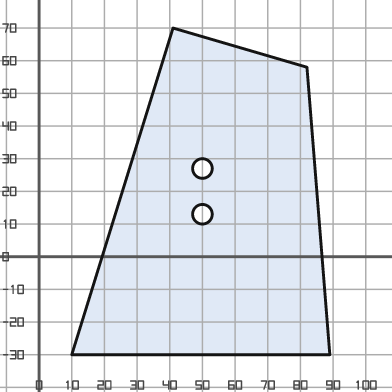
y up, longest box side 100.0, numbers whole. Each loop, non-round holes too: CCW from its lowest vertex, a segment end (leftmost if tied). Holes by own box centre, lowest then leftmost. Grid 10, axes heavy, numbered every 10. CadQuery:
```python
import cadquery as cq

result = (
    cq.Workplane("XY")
    .moveTo(10.0, -30.0)
    .lineTo(89.0, -30.0)
    .lineTo(82.0, 58.0)
    .lineTo(41.0, 70.0)
    .close()
    .moveTo(50.0, 13.0)
    .circle(3.0)
    .moveTo(50.0, 27.0)
    .circle(3.0)
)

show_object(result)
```